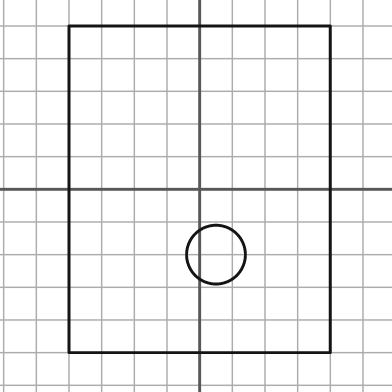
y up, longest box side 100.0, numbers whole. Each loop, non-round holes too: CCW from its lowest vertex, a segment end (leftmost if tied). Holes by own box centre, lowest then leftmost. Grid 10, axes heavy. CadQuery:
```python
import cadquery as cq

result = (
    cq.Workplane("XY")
    .moveTo(-40.0, -50.0)
    .lineTo(40.0, -50.0)
    .lineTo(40.0, 50.0)
    .lineTo(-40.0, 50.0)
    .close()
    .moveTo(5.0, -20.0)
    .circle(9.0)
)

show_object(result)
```